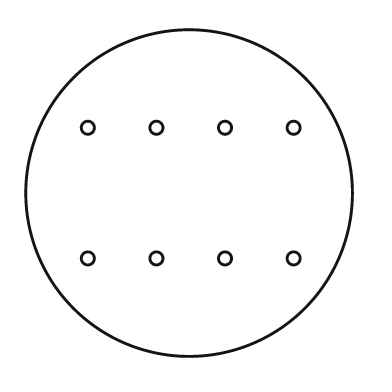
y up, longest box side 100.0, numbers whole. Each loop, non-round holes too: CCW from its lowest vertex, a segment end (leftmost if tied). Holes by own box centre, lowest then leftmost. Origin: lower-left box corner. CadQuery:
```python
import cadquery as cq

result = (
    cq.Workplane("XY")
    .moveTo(50.0, 50.0)
    .circle(50.0)
    .moveTo(19.0, 30.0)
    .circle(2.0)
    .moveTo(40.0, 30.0)
    .circle(2.0)
    .moveTo(61.0, 30.0)
    .circle(2.0)
    .moveTo(82.0, 30.0)
    .circle(2.0)
    .moveTo(19.0, 70.0)
    .circle(2.0)
    .moveTo(40.0, 70.0)
    .circle(2.0)
    .moveTo(61.0, 70.0)
    .circle(2.0)
    .moveTo(82.0, 70.0)
    .circle(2.0)
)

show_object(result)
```